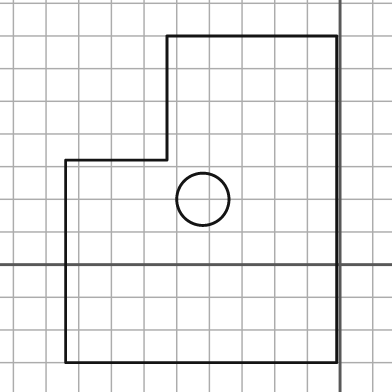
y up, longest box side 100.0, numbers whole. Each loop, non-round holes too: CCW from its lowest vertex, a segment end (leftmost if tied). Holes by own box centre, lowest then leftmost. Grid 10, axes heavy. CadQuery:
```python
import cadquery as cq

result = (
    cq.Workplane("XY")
    .moveTo(-84.0, -30.0)
    .lineTo(-1.0, -30.0)
    .lineTo(-1.0, 70.0)
    .lineTo(-53.0, 70.0)
    .lineTo(-53.0, 32.0)
    .lineTo(-84.0, 32.0)
    .close()
    .moveTo(-42.0, 20.0)
    .circle(8.0)
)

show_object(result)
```